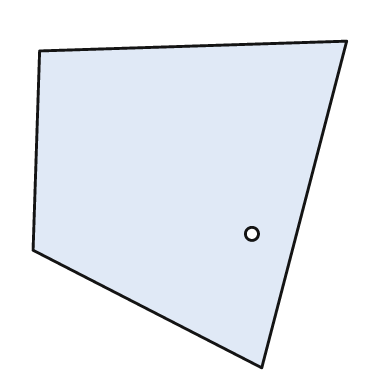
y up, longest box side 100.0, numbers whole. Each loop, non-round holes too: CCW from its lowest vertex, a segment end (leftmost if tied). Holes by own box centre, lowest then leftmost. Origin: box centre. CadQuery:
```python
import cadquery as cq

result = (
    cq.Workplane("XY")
    .moveTo(22.0, -50.0)
    .lineTo(48.0, 50.0)
    .lineTo(-46.0, 47.0)
    .lineTo(-48.0, -14.0)
    .close()
    .moveTo(19.0, -9.0)
    .circle(2.0)
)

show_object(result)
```